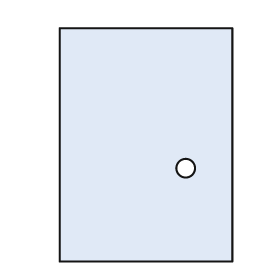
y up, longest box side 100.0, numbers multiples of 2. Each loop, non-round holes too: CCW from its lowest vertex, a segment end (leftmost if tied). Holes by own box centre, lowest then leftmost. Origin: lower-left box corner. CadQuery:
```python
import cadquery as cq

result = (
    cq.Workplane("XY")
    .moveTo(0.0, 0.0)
    .lineTo(74.0, 0.0)
    .lineTo(74.0, 100.0)
    .lineTo(0.0, 100.0)
    .close()
    .moveTo(54.0, 40.0)
    .circle(4.0)
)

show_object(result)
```